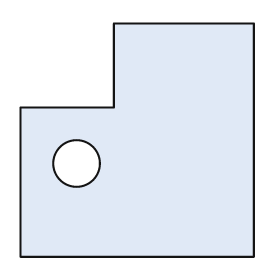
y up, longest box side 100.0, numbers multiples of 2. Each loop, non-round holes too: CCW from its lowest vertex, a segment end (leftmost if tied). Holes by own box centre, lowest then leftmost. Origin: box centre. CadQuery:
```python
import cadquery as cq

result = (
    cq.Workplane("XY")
    .moveTo(-50.0, -50.0)
    .lineTo(50.0, -50.0)
    .lineTo(50.0, 50.0)
    .lineTo(-10.0, 50.0)
    .lineTo(-10.0, 14.0)
    .lineTo(-50.0, 14.0)
    .close()
    .moveTo(-26.0, -10.0)
    .circle(10.0)
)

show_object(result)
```